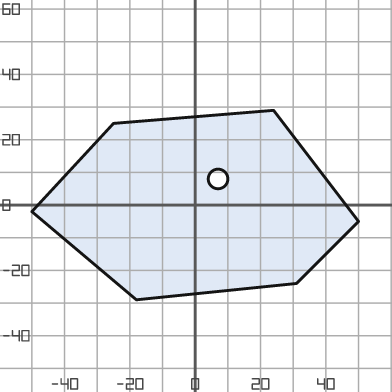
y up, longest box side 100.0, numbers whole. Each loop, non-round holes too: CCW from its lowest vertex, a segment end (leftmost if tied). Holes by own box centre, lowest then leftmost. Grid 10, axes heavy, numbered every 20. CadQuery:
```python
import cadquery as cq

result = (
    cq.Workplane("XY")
    .moveTo(-18.0, -29.0)
    .lineTo(31.0, -24.0)
    .lineTo(50.0, -5.0)
    .lineTo(24.0, 29.0)
    .lineTo(-25.0, 25.0)
    .lineTo(-50.0, -2.0)
    .close()
    .moveTo(7.0, 8.0)
    .circle(3.0)
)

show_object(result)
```